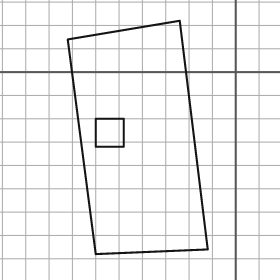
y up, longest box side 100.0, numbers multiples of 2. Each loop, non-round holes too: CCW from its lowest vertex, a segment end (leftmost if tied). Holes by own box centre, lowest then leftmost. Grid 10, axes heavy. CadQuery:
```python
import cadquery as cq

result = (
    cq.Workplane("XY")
    .moveTo(-60.0, -78.0)
    .lineTo(-12.0, -76.0)
    .lineTo(-24.0, 22.0)
    .lineTo(-72.0, 14.0)
    .close()
    .moveTo(-60.0, -32.0)
    .lineTo(-48.0, -32.0)
    .lineTo(-48.0, -20.0)
    .lineTo(-60.0, -20.0)
    .close()
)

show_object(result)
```